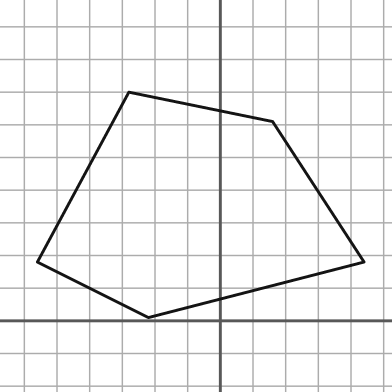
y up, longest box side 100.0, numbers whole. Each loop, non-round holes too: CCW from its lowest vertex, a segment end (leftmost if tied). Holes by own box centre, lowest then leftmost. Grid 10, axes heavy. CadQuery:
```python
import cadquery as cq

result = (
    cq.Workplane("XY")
    .moveTo(-22.0, 1.0)
    .lineTo(44.0, 18.0)
    .lineTo(16.0, 61.0)
    .lineTo(-28.0, 70.0)
    .lineTo(-56.0, 18.0)
    .close()
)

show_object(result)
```